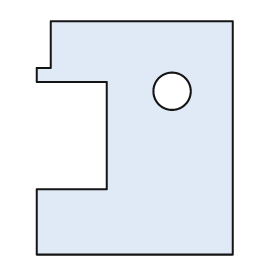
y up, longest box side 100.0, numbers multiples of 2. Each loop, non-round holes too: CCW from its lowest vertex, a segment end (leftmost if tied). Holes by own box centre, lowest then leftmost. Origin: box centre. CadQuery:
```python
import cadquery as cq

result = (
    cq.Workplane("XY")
    .moveTo(-42.0, -50.0)
    .lineTo(42.0, -50.0)
    .lineTo(42.0, 50.0)
    .lineTo(-36.0, 50.0)
    .lineTo(-36.0, 30.0)
    .lineTo(-42.0, 30.0)
    .lineTo(-42.0, 24.0)
    .lineTo(-12.0, 24.0)
    .lineTo(-12.0, -22.0)
    .lineTo(-42.0, -22.0)
    .close()
    .moveTo(16.0, 20.0)
    .circle(8.0)
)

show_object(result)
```